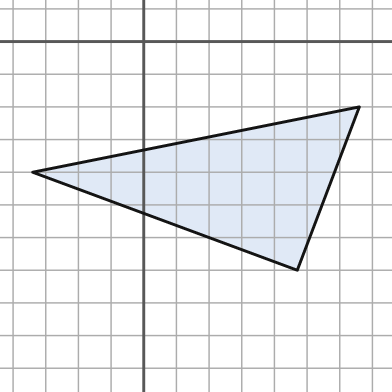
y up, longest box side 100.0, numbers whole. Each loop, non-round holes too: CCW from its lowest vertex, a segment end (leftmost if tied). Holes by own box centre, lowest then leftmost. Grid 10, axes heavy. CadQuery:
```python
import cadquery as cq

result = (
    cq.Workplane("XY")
    .moveTo(47.0, -70.0)
    .lineTo(66.0, -20.0)
    .lineTo(-34.0, -40.0)
    .close()
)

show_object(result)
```